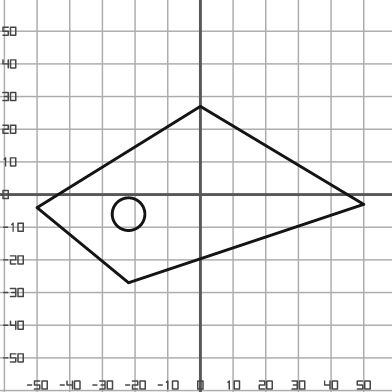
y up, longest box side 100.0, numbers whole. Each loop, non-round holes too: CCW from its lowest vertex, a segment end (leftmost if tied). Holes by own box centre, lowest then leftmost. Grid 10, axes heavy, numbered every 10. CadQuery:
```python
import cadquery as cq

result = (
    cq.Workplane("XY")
    .moveTo(-22.0, -27.0)
    .lineTo(50.0, -3.0)
    .lineTo(0.0, 27.0)
    .lineTo(-50.0, -4.0)
    .close()
    .moveTo(-22.0, -6.0)
    .circle(5.0)
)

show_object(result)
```